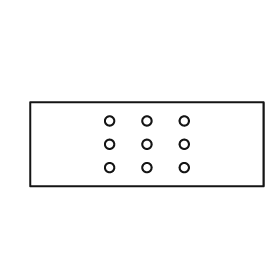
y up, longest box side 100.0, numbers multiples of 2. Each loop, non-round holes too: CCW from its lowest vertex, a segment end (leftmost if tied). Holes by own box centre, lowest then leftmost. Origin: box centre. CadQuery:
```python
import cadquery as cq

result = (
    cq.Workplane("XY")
    .moveTo(-50.0, -18.0)
    .lineTo(50.0, -18.0)
    .lineTo(50.0, 18.0)
    .lineTo(-50.0, 18.0)
    .close()
    .moveTo(-16.0, -10.0)
    .circle(2.0)
    .moveTo(0.0, -10.0)
    .circle(2.0)
    .moveTo(16.0, -10.0)
    .circle(2.0)
    .moveTo(-16.0, 0.0)
    .circle(2.0)
    .moveTo(0.0, 0.0)
    .circle(2.0)
    .moveTo(16.0, 0.0)
    .circle(2.0)
    .moveTo(-16.0, 10.0)
    .circle(2.0)
    .moveTo(0.0, 10.0)
    .circle(2.0)
    .moveTo(16.0, 10.0)
    .circle(2.0)
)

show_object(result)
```